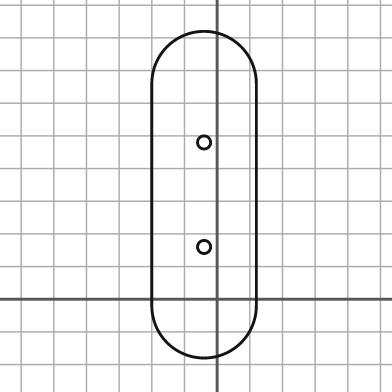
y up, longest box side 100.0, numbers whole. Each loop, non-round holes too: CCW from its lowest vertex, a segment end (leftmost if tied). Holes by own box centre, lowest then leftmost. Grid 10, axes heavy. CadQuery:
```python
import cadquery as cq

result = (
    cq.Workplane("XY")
    .moveTo(-20.0, -2.0)
    .threePointArc((-4.0, -18.0), (12.0, -2.0))
    .lineTo(12.0, 66.0)
    .threePointArc((-4.0, 82.0), (-20.0, 66.0))
    .close()
    .moveTo(-4.0, 16.0)
    .circle(2.0)
    .moveTo(-4.0, 48.0)
    .circle(2.0)
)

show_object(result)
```